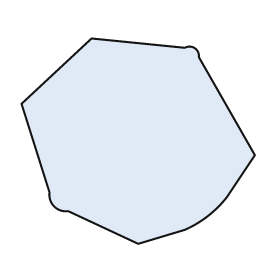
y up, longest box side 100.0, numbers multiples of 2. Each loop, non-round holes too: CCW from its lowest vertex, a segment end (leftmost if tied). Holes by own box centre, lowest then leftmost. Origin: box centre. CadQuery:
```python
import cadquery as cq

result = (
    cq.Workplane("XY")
    .moveTo(0.0, -44.0)
    .lineTo(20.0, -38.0)
    .threePointArc((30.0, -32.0), (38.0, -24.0))
    .lineTo(50.0, -6.0)
    .lineTo(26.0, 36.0)
    .threePointArc((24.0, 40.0), (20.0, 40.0))
    .lineTo(-20.0, 44.0)
    .lineTo(-50.0, 16.0)
    .lineTo(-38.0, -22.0)
    .threePointArc((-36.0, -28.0), (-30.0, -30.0))
    .close()
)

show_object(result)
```